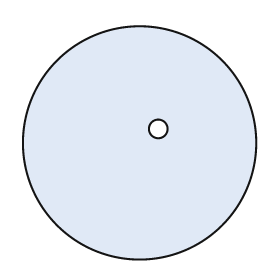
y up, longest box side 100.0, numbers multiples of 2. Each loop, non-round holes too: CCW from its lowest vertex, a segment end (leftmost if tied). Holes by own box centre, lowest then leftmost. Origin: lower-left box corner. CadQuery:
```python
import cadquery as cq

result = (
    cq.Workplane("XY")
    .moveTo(50.0, 50.0)
    .circle(50.0)
    .moveTo(58.0, 56.0)
    .circle(4.0)
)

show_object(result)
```